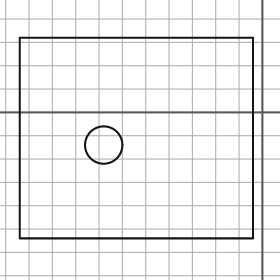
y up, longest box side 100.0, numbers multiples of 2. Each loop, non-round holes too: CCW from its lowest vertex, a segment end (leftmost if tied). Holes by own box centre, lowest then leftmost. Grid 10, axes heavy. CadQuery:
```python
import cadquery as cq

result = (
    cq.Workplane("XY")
    .moveTo(-104.0, -54.0)
    .lineTo(-4.0, -54.0)
    .lineTo(-4.0, 32.0)
    .lineTo(-104.0, 32.0)
    .close()
    .moveTo(-68.0, -14.0)
    .circle(8.0)
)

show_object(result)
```